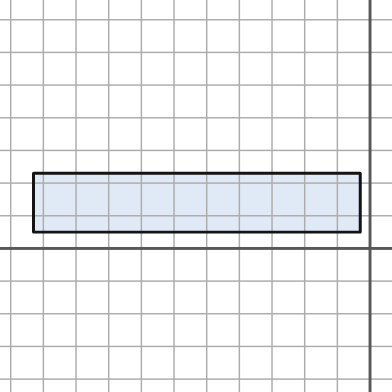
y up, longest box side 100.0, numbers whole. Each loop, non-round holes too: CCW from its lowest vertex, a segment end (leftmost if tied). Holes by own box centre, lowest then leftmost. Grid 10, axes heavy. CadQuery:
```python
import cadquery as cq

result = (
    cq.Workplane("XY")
    .moveTo(-103.0, 5.0)
    .lineTo(-3.0, 5.0)
    .lineTo(-3.0, 23.0)
    .lineTo(-103.0, 23.0)
    .close()
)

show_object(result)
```